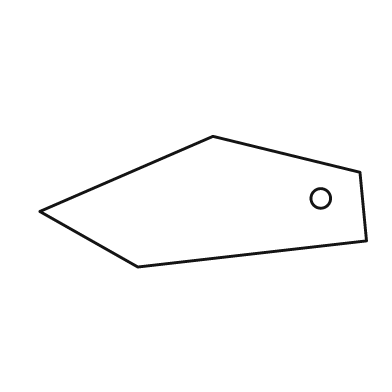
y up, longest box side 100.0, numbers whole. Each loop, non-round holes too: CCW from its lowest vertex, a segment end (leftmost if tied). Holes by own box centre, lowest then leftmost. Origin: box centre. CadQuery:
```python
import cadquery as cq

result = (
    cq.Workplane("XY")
    .moveTo(-20.0, -20.0)
    .lineTo(50.0, -12.0)
    .lineTo(48.0, 9.0)
    .lineTo(3.0, 20.0)
    .lineTo(-50.0, -3.0)
    .close()
    .moveTo(36.0, 1.0)
    .circle(3.0)
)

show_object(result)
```